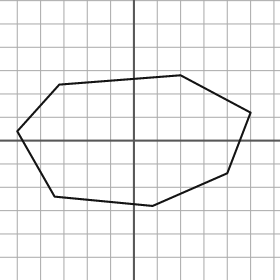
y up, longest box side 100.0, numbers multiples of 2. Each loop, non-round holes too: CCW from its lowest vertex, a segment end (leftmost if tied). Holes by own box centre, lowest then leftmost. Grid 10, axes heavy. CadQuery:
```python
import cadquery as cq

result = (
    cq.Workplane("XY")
    .moveTo(8.0, -28.0)
    .lineTo(40.0, -14.0)
    .lineTo(50.0, 12.0)
    .lineTo(20.0, 28.0)
    .lineTo(-32.0, 24.0)
    .lineTo(-50.0, 4.0)
    .lineTo(-34.0, -24.0)
    .close()
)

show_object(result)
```